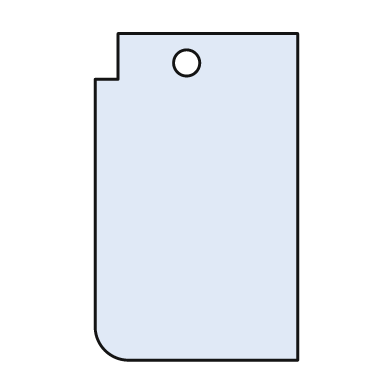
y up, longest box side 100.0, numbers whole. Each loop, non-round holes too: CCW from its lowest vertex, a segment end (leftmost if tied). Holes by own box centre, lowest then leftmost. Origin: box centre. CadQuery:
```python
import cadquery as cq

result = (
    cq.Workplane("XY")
    .moveTo(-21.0, -50.0)
    .lineTo(31.0, -50.0)
    .lineTo(31.0, 50.0)
    .lineTo(-24.0, 50.0)
    .lineTo(-24.0, 36.0)
    .lineTo(-31.0, 36.0)
    .lineTo(-31.0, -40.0)
    .threePointArc((-28.0, -47.0), (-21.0, -50.0))
    .close()
    .moveTo(-3.0, 41.0)
    .circle(4.0)
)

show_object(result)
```